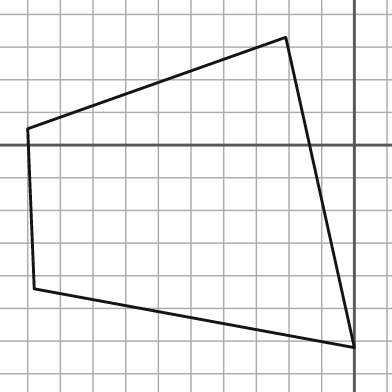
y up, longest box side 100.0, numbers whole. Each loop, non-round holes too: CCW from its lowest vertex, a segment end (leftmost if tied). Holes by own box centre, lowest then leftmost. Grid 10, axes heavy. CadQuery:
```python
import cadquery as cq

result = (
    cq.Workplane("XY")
    .moveTo(0.0, -62.0)
    .lineTo(-21.0, 33.0)
    .lineTo(-100.0, 5.0)
    .lineTo(-98.0, -44.0)
    .close()
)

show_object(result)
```